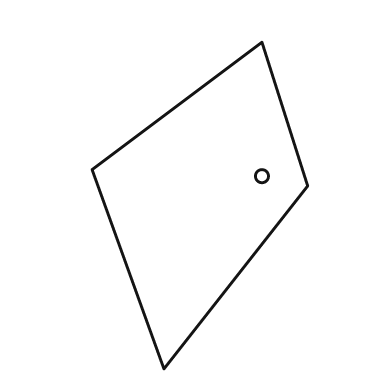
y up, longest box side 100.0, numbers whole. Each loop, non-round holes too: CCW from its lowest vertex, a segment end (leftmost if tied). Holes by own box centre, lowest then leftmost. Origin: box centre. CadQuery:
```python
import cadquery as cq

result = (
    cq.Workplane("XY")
    .moveTo(-11.0, -50.0)
    .lineTo(33.0, 6.0)
    .lineTo(19.0, 50.0)
    .lineTo(-33.0, 11.0)
    .close()
    .moveTo(19.0, 9.0)
    .circle(2.0)
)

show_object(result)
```